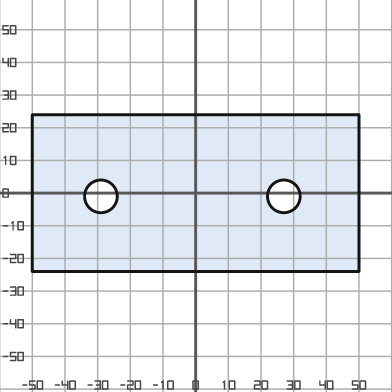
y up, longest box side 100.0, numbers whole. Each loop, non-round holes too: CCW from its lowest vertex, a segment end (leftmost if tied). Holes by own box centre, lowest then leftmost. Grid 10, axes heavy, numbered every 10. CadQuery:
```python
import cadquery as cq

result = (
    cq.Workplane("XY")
    .moveTo(-50.0, -24.0)
    .lineTo(50.0, -24.0)
    .lineTo(50.0, 24.0)
    .lineTo(-50.0, 24.0)
    .close()
    .moveTo(-29.0, -1.0)
    .circle(5.0)
    .moveTo(27.0, -1.0)
    .circle(5.0)
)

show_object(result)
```